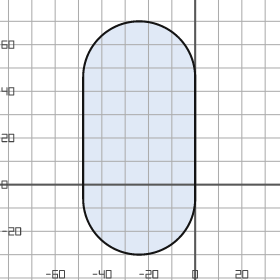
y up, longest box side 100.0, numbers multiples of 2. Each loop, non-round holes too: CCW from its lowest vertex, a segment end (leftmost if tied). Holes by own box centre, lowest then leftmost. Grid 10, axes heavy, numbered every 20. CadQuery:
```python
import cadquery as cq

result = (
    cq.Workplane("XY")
    .moveTo(-48.0, -6.0)
    .threePointArc((-24.0, -30.0), (0.0, -6.0))
    .lineTo(0.0, 46.0)
    .threePointArc((-24.0, 70.0), (-48.0, 46.0))
    .close()
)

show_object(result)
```